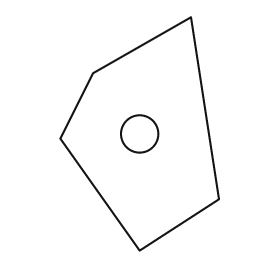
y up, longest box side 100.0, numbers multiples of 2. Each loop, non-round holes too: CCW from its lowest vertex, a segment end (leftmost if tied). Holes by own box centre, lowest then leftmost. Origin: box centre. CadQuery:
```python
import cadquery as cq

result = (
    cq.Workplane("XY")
    .moveTo(0.0, -50.0)
    .lineTo(34.0, -28.0)
    .lineTo(22.0, 50.0)
    .lineTo(-20.0, 26.0)
    .lineTo(-34.0, -2.0)
    .close()
    .moveTo(0.0, 0.0)
    .circle(8.0)
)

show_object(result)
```